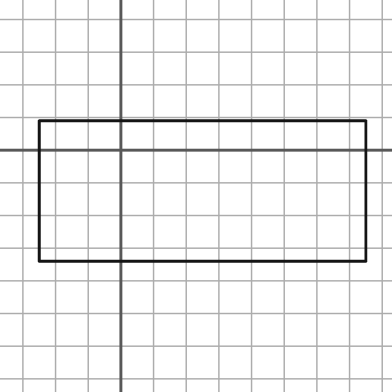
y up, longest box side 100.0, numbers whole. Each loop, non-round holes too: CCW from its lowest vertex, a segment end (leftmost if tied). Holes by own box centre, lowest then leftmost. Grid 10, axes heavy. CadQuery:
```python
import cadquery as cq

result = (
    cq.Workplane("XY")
    .moveTo(-25.0, -34.0)
    .lineTo(75.0, -34.0)
    .lineTo(75.0, 9.0)
    .lineTo(-25.0, 9.0)
    .close()
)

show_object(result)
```